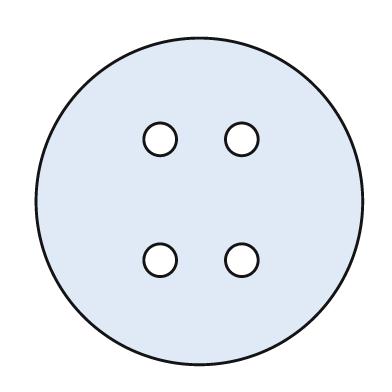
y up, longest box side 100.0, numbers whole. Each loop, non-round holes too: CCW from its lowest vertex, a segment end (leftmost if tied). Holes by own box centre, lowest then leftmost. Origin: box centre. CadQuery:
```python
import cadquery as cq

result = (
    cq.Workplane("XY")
    .moveTo(0.0, 0.0)
    .circle(50.0)
    .moveTo(-12.0, -18.0)
    .circle(5.0)
    .moveTo(13.0, -18.0)
    .circle(5.0)
    .moveTo(-12.0, 19.0)
    .circle(5.0)
    .moveTo(13.0, 19.0)
    .circle(5.0)
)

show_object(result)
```